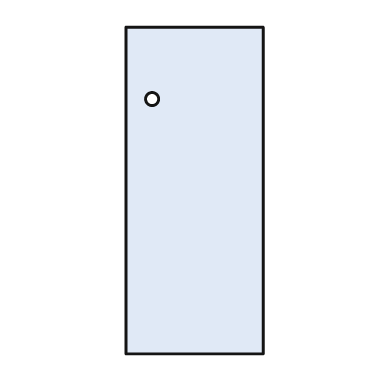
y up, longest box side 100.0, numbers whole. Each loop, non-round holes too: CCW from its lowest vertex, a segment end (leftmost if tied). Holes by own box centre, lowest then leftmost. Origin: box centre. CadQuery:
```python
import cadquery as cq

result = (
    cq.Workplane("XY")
    .moveTo(-21.0, -50.0)
    .lineTo(21.0, -50.0)
    .lineTo(21.0, 50.0)
    .lineTo(-21.0, 50.0)
    .close()
    .moveTo(-13.0, 28.0)
    .circle(2.0)
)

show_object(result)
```